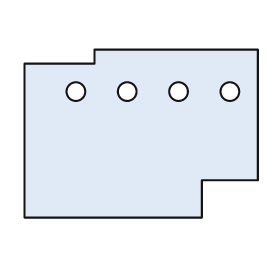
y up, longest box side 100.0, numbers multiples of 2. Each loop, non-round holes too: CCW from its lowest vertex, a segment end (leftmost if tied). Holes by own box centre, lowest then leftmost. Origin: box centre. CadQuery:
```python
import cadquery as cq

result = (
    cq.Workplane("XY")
    .moveTo(-50.0, -36.0)
    .lineTo(26.0, -36.0)
    .lineTo(26.0, -20.0)
    .lineTo(50.0, -20.0)
    .lineTo(50.0, 36.0)
    .lineTo(-20.0, 36.0)
    .lineTo(-20.0, 30.0)
    .lineTo(-50.0, 30.0)
    .close()
    .moveTo(-28.0, 18.0)
    .circle(4.0)
    .moveTo(-6.0, 18.0)
    .circle(4.0)
    .moveTo(16.0, 18.0)
    .circle(4.0)
    .moveTo(38.0, 18.0)
    .circle(4.0)
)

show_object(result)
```